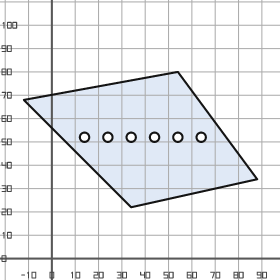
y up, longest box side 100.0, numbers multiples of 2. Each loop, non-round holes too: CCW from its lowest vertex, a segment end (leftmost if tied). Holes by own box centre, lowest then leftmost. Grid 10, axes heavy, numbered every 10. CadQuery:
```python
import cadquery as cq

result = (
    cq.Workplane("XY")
    .moveTo(34.0, 22.0)
    .lineTo(88.0, 34.0)
    .lineTo(54.0, 80.0)
    .lineTo(-12.0, 68.0)
    .close()
    .moveTo(14.0, 52.0)
    .circle(2.0)
    .moveTo(24.0, 52.0)
    .circle(2.0)
    .moveTo(34.0, 52.0)
    .circle(2.0)
    .moveTo(44.0, 52.0)
    .circle(2.0)
    .moveTo(54.0, 52.0)
    .circle(2.0)
    .moveTo(64.0, 52.0)
    .circle(2.0)
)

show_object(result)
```